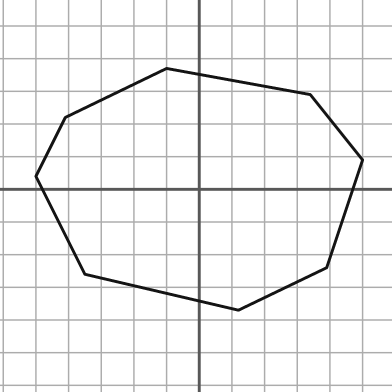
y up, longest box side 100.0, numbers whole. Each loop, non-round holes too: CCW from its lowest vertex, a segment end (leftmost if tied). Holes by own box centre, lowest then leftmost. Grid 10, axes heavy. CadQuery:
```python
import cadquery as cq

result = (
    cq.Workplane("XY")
    .moveTo(12.0, -37.0)
    .lineTo(39.0, -24.0)
    .lineTo(50.0, 9.0)
    .lineTo(34.0, 29.0)
    .lineTo(-10.0, 37.0)
    .lineTo(-41.0, 22.0)
    .lineTo(-50.0, 4.0)
    .lineTo(-35.0, -26.0)
    .close()
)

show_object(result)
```